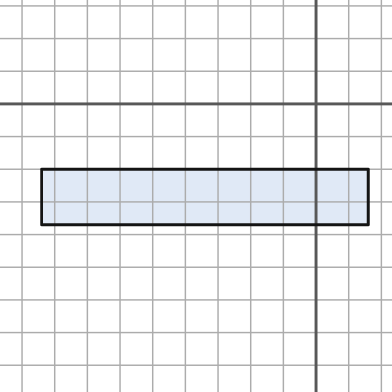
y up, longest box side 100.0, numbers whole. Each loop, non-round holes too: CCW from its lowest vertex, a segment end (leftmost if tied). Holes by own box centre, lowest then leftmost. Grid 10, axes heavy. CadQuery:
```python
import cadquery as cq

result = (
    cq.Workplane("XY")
    .moveTo(-84.0, -37.0)
    .lineTo(16.0, -37.0)
    .lineTo(16.0, -20.0)
    .lineTo(-84.0, -20.0)
    .close()
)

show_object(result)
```